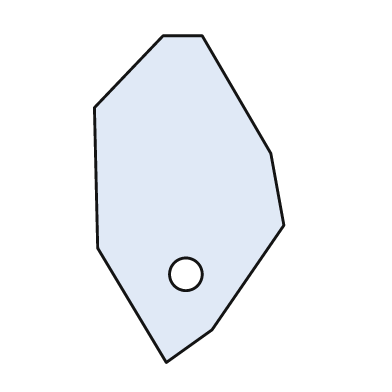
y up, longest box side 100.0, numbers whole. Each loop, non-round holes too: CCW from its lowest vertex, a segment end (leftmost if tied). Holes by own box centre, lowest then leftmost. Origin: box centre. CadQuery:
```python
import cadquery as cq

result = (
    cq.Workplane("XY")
    .moveTo(-7.0, -50.0)
    .lineTo(7.0, -40.0)
    .lineTo(29.0, -8.0)
    .lineTo(25.0, 14.0)
    .lineTo(4.0, 50.0)
    .lineTo(-8.0, 50.0)
    .lineTo(-29.0, 28.0)
    .lineTo(-28.0, -15.0)
    .close()
    .moveTo(-1.0, -23.0)
    .circle(5.0)
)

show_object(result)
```